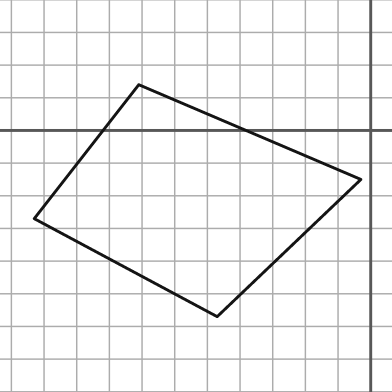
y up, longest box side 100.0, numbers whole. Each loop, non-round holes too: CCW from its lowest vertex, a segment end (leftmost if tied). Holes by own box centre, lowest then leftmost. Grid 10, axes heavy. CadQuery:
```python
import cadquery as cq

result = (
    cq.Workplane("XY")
    .moveTo(-47.0, -57.0)
    .lineTo(-3.0, -15.0)
    .lineTo(-71.0, 14.0)
    .lineTo(-103.0, -27.0)
    .close()
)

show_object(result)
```